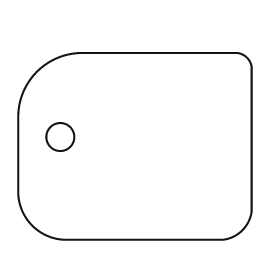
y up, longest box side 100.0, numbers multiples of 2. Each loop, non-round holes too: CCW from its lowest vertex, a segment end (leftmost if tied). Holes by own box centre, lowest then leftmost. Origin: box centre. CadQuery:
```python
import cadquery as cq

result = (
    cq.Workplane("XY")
    .moveTo(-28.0, -40.0)
    .lineTo(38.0, -40.0)
    .threePointArc((46.0, -36.0), (50.0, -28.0))
    .lineTo(50.0, 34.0)
    .threePointArc((48.0, 38.0), (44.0, 40.0))
    .lineTo(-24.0, 40.0)
    .threePointArc((-42.0, 32.0), (-50.0, 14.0))
    .lineTo(-50.0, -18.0)
    .threePointArc((-44.0, -34.0), (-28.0, -40.0))
    .close()
    .moveTo(-32.0, 4.0)
    .circle(6.0)
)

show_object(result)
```